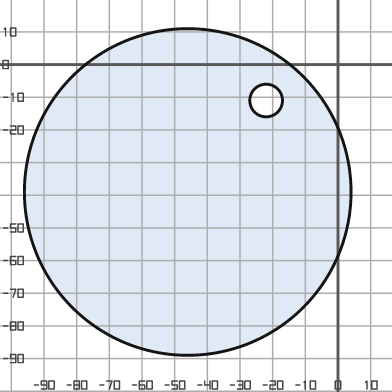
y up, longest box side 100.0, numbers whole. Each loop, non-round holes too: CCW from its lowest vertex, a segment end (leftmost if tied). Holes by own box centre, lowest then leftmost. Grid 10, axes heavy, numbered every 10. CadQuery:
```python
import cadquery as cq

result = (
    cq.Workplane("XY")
    .moveTo(-46.0, -39.0)
    .circle(50.0)
    .moveTo(-22.0, -11.0)
    .circle(5.0)
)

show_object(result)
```